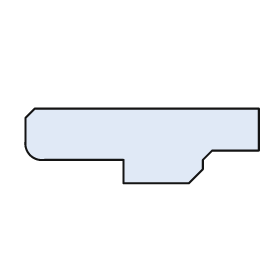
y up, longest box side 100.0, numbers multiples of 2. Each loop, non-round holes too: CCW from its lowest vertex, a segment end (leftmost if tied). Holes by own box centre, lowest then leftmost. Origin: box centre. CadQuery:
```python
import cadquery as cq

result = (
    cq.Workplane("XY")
    .moveTo(-8.0, -16.0)
    .lineTo(20.0, -16.0)
    .lineTo(26.0, -10.0)
    .lineTo(26.0, -6.0)
    .lineTo(30.0, -2.0)
    .lineTo(50.0, -2.0)
    .lineTo(50.0, 16.0)
    .lineTo(-46.0, 16.0)
    .lineTo(-50.0, 12.0)
    .lineTo(-50.0, 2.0)
    .threePointArc((-48.0, -4.0), (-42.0, -6.0))
    .lineTo(-8.0, -6.0)
    .close()
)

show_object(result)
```